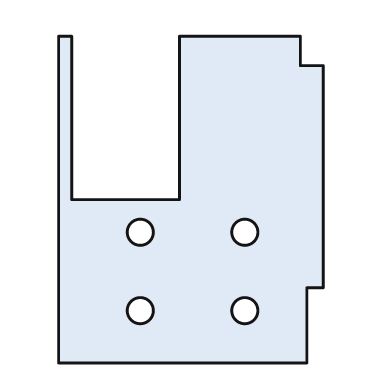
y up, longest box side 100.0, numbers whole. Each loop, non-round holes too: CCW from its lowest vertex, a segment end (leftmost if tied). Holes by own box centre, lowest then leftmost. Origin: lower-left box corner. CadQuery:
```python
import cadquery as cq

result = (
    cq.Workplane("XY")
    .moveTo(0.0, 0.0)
    .lineTo(76.0, 0.0)
    .lineTo(76.0, 23.0)
    .lineTo(81.0, 23.0)
    .lineTo(81.0, 91.0)
    .lineTo(74.0, 91.0)
    .lineTo(74.0, 100.0)
    .lineTo(37.0, 100.0)
    .lineTo(37.0, 50.0)
    .lineTo(4.0, 50.0)
    .lineTo(4.0, 100.0)
    .lineTo(0.0, 100.0)
    .close()
    .moveTo(25.0, 16.0)
    .circle(4.0)
    .moveTo(57.0, 16.0)
    .circle(4.0)
    .moveTo(25.0, 40.0)
    .circle(4.0)
    .moveTo(57.0, 40.0)
    .circle(4.0)
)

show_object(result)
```